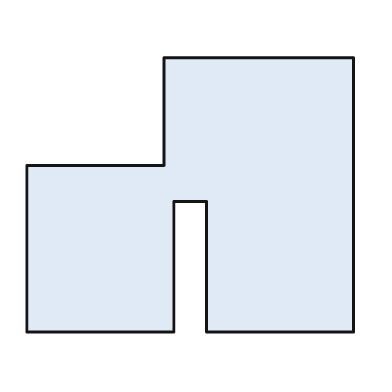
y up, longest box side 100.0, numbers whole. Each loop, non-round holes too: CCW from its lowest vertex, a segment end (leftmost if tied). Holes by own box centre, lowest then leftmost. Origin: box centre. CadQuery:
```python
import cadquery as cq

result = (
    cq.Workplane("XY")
    .moveTo(-50.0, -42.0)
    .lineTo(-5.0, -42.0)
    .lineTo(-5.0, -2.0)
    .lineTo(5.0, -2.0)
    .lineTo(5.0, -42.0)
    .lineTo(50.0, -42.0)
    .lineTo(50.0, 42.0)
    .lineTo(-8.0, 42.0)
    .lineTo(-8.0, 9.0)
    .lineTo(-50.0, 9.0)
    .close()
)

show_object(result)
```